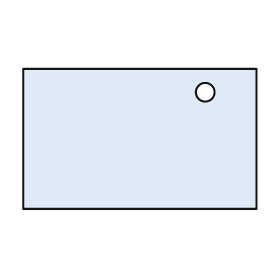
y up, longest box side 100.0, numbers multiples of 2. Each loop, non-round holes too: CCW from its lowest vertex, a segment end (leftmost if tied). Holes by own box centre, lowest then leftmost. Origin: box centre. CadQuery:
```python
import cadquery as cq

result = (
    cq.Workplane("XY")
    .moveTo(-50.0, -30.0)
    .lineTo(50.0, -30.0)
    .lineTo(50.0, 30.0)
    .lineTo(-50.0, 30.0)
    .close()
    .moveTo(28.0, 20.0)
    .circle(4.0)
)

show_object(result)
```